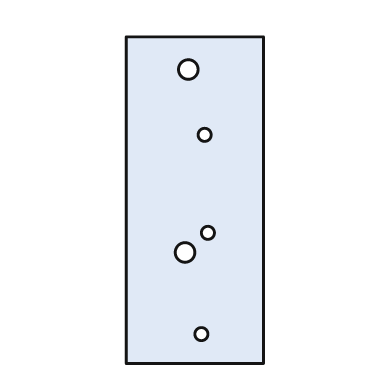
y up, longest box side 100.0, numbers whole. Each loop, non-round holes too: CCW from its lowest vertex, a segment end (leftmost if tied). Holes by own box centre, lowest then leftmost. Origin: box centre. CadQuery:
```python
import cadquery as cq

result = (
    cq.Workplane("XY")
    .moveTo(-21.0, -50.0)
    .lineTo(21.0, -50.0)
    .lineTo(21.0, 50.0)
    .lineTo(-21.0, 50.0)
    .close()
    .moveTo(2.0, -41.0)
    .circle(2.0)
    .moveTo(-3.0, -16.0)
    .circle(3.0)
    .moveTo(4.0, -10.0)
    .circle(2.0)
    .moveTo(3.0, 20.0)
    .circle(2.0)
    .moveTo(-2.0, 40.0)
    .circle(3.0)
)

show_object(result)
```